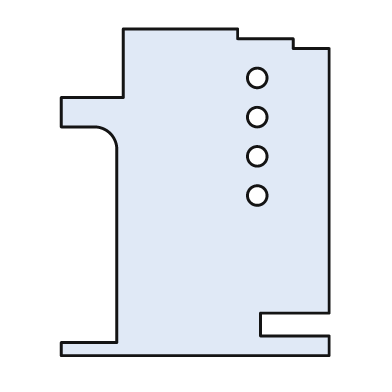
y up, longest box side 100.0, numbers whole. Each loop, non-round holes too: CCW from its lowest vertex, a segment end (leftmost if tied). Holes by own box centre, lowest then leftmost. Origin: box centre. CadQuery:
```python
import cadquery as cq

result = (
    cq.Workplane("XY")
    .moveTo(-41.0, -50.0)
    .lineTo(41.0, -50.0)
    .lineTo(41.0, -44.0)
    .lineTo(20.0, -44.0)
    .lineTo(20.0, -37.0)
    .lineTo(41.0, -37.0)
    .lineTo(41.0, 44.0)
    .lineTo(30.0, 44.0)
    .lineTo(30.0, 47.0)
    .lineTo(13.0, 47.0)
    .lineTo(13.0, 50.0)
    .lineTo(-22.0, 50.0)
    .lineTo(-22.0, 29.0)
    .lineTo(-41.0, 29.0)
    .lineTo(-41.0, 20.0)
    .lineTo(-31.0, 20.0)
    .threePointArc((-26.0, 18.0), (-24.0, 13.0))
    .lineTo(-24.0, -46.0)
    .lineTo(-41.0, -46.0)
    .close()
    .moveTo(19.0, -1.0)
    .circle(3.0)
    .moveTo(19.0, 11.0)
    .circle(3.0)
    .moveTo(19.0, 23.0)
    .circle(3.0)
    .moveTo(19.0, 35.0)
    .circle(3.0)
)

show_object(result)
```